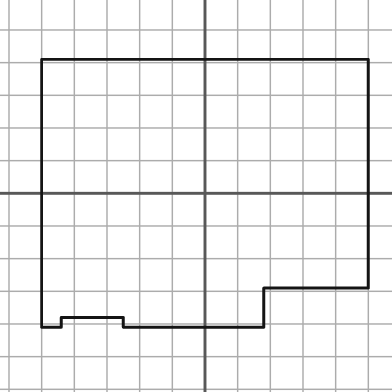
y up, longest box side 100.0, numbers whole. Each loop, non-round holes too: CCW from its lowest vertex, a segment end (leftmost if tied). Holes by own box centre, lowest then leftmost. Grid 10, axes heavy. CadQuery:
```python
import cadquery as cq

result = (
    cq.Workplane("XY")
    .moveTo(-50.0, -41.0)
    .lineTo(-44.0, -41.0)
    .lineTo(-44.0, -38.0)
    .lineTo(-25.0, -38.0)
    .lineTo(-25.0, -41.0)
    .lineTo(18.0, -41.0)
    .lineTo(18.0, -29.0)
    .lineTo(50.0, -29.0)
    .lineTo(50.0, 41.0)
    .lineTo(-50.0, 41.0)
    .close()
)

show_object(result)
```